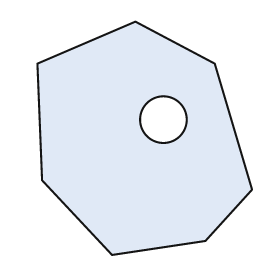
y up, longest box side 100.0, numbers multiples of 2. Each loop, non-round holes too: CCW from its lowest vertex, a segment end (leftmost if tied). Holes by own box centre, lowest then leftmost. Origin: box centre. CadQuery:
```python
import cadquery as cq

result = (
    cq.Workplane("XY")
    .moveTo(-14.0, -50.0)
    .lineTo(26.0, -44.0)
    .lineTo(46.0, -22.0)
    .lineTo(30.0, 32.0)
    .lineTo(-4.0, 50.0)
    .lineTo(-46.0, 32.0)
    .lineTo(-44.0, -18.0)
    .close()
    .moveTo(8.0, 8.0)
    .circle(10.0)
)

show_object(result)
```